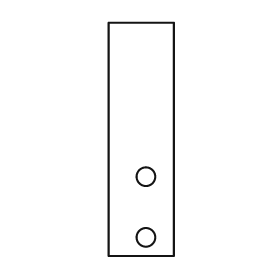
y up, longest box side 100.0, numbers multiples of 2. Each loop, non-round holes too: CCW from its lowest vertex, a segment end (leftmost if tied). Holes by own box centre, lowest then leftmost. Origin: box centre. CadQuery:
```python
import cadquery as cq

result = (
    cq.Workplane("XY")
    .moveTo(-14.0, -50.0)
    .lineTo(14.0, -50.0)
    .lineTo(14.0, 50.0)
    .lineTo(-14.0, 50.0)
    .close()
    .moveTo(2.0, -42.0)
    .circle(4.0)
    .moveTo(2.0, -16.0)
    .circle(4.0)
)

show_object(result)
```